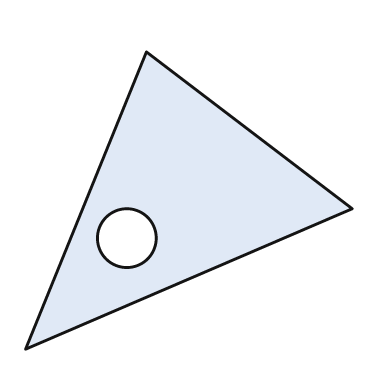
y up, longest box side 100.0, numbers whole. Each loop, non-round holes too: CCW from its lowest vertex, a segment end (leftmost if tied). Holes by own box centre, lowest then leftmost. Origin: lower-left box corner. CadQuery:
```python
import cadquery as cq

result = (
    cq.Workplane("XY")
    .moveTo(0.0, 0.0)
    .lineTo(100.0, 43.0)
    .lineTo(37.0, 91.0)
    .close()
    .moveTo(31.0, 34.0)
    .circle(9.0)
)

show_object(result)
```